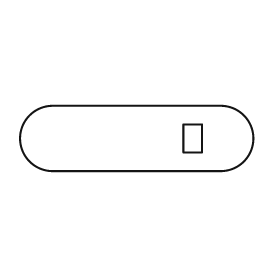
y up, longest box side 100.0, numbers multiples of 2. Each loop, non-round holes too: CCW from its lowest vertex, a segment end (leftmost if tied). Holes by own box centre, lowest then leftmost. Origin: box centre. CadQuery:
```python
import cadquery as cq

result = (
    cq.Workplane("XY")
    .moveTo(-36.0, -14.0)
    .lineTo(36.0, -14.0)
    .threePointArc((50.0, 0.0), (36.0, 14.0))
    .lineTo(-36.0, 14.0)
    .threePointArc((-50.0, 0.0), (-36.0, -14.0))
    .close()
    .moveTo(20.0, -6.0)
    .lineTo(28.0, -6.0)
    .lineTo(28.0, 6.0)
    .lineTo(20.0, 6.0)
    .close()
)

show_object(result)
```